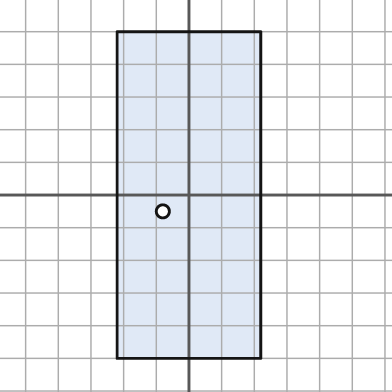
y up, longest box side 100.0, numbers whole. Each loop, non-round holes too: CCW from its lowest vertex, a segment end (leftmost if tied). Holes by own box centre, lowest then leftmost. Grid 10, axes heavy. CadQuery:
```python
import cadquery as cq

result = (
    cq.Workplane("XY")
    .moveTo(-22.0, -50.0)
    .lineTo(22.0, -50.0)
    .lineTo(22.0, 50.0)
    .lineTo(-22.0, 50.0)
    .close()
    .moveTo(-8.0, -5.0)
    .circle(2.0)
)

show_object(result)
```